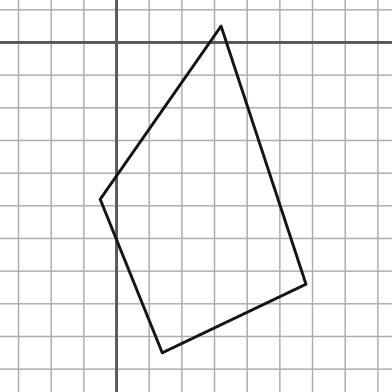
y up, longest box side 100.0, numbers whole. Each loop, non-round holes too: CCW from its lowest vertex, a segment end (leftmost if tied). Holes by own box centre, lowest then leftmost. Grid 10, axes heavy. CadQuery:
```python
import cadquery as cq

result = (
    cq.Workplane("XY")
    .moveTo(14.0, -95.0)
    .lineTo(58.0, -74.0)
    .lineTo(32.0, 5.0)
    .lineTo(-5.0, -48.0)
    .close()
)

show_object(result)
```